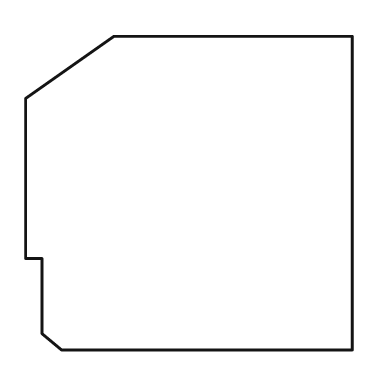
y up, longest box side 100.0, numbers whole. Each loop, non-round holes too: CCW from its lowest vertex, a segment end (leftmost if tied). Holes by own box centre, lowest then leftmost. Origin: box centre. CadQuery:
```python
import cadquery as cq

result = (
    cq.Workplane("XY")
    .moveTo(-39.0, -48.0)
    .lineTo(50.0, -48.0)
    .lineTo(50.0, 48.0)
    .lineTo(-23.0, 48.0)
    .lineTo(-50.0, 29.0)
    .lineTo(-50.0, -20.0)
    .lineTo(-45.0, -20.0)
    .lineTo(-45.0, -43.0)
    .close()
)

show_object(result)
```